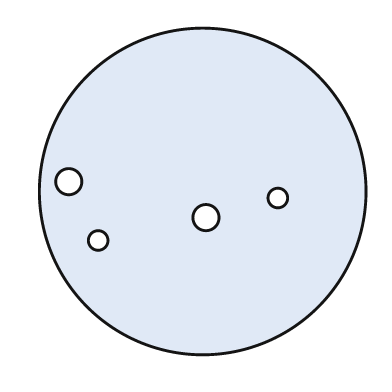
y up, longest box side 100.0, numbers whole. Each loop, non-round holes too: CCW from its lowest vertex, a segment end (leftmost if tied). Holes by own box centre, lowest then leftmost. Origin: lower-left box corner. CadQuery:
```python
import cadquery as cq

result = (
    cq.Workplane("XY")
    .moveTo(50.0, 50.0)
    .circle(50.0)
    .moveTo(18.0, 35.0)
    .circle(3.0)
    .moveTo(51.0, 42.0)
    .circle(4.0)
    .moveTo(73.0, 48.0)
    .circle(3.0)
    .moveTo(9.0, 53.0)
    .circle(4.0)
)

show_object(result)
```